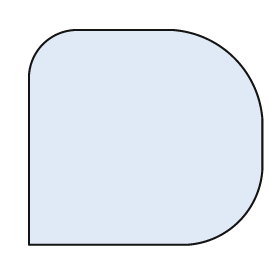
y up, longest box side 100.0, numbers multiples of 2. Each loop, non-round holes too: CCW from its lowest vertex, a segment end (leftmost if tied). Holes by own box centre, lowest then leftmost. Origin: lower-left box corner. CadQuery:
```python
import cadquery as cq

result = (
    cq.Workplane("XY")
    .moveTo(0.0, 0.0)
    .lineTo(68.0, 0.0)
    .threePointArc((90.0, 10.0), (100.0, 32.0))
    .lineTo(100.0, 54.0)
    .threePointArc((88.0, 80.0), (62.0, 92.0))
    .lineTo(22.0, 92.0)
    .threePointArc((6.0, 86.0), (0.0, 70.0))
    .close()
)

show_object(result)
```